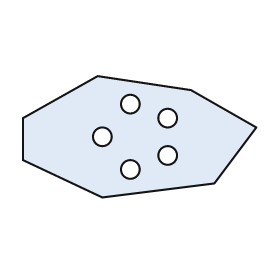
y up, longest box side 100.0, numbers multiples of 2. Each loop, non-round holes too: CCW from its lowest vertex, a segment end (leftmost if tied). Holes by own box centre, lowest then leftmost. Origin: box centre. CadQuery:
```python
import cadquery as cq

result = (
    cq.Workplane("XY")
    .moveTo(-16.0, -26.0)
    .lineTo(32.0, -20.0)
    .lineTo(50.0, 4.0)
    .lineTo(22.0, 20.0)
    .lineTo(-18.0, 26.0)
    .lineTo(-50.0, 8.0)
    .lineTo(-50.0, -10.0)
    .close()
    .moveTo(-4.0, -14.0)
    .circle(4.0)
    .moveTo(12.0, -8.0)
    .circle(4.0)
    .moveTo(-16.0, 0.0)
    .circle(4.0)
    .moveTo(12.0, 8.0)
    .circle(4.0)
    .moveTo(-4.0, 14.0)
    .circle(4.0)
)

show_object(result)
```